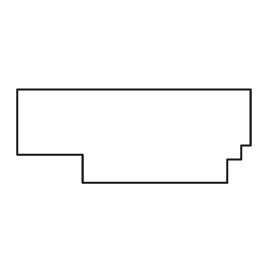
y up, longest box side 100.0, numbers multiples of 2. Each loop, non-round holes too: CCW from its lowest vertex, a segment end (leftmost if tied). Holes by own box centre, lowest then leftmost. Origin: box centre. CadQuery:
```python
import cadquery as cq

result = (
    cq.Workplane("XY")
    .moveTo(-22.0, -20.0)
    .lineTo(40.0, -20.0)
    .lineTo(40.0, -10.0)
    .lineTo(46.0, -10.0)
    .lineTo(46.0, -4.0)
    .lineTo(50.0, -4.0)
    .lineTo(50.0, 20.0)
    .lineTo(-50.0, 20.0)
    .lineTo(-50.0, -8.0)
    .lineTo(-22.0, -8.0)
    .close()
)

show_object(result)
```